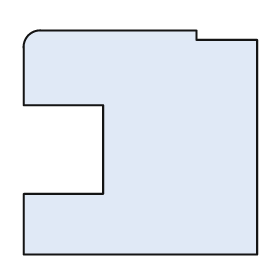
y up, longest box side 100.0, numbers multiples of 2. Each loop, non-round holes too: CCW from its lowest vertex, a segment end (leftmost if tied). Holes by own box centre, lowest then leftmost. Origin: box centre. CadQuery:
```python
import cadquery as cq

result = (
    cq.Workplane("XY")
    .moveTo(-50.0, -48.0)
    .lineTo(50.0, -48.0)
    .lineTo(50.0, 44.0)
    .lineTo(24.0, 44.0)
    .lineTo(24.0, 48.0)
    .lineTo(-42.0, 48.0)
    .threePointArc((-48.0, 46.0), (-50.0, 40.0))
    .lineTo(-50.0, 16.0)
    .lineTo(-16.0, 16.0)
    .lineTo(-16.0, -22.0)
    .lineTo(-50.0, -22.0)
    .close()
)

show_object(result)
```